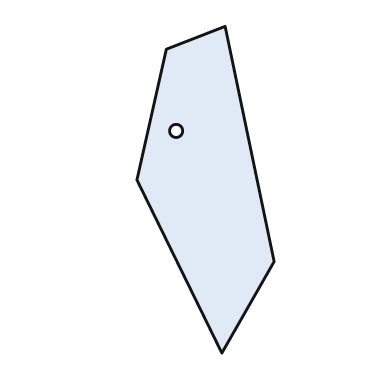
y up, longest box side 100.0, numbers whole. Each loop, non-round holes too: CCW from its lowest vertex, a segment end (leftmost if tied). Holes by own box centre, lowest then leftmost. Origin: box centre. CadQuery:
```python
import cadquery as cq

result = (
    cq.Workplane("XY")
    .moveTo(5.0, -50.0)
    .lineTo(21.0, -22.0)
    .lineTo(6.0, 50.0)
    .lineTo(-12.0, 43.0)
    .lineTo(-21.0, 3.0)
    .close()
    .moveTo(-9.0, 18.0)
    .circle(2.0)
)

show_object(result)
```